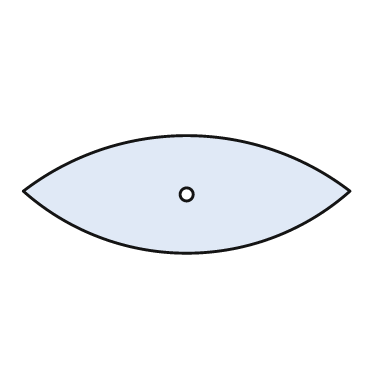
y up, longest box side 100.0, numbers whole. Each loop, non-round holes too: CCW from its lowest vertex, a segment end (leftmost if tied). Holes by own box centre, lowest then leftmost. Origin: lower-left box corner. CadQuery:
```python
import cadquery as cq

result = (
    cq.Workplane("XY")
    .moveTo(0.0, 19.0)
    .threePointArc((50.0, 0.0), (100.0, 19.0))
    .threePointArc((50.0, 36.0), (0.0, 19.0))
    .close()
    .moveTo(50.0, 18.0)
    .circle(2.0)
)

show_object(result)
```